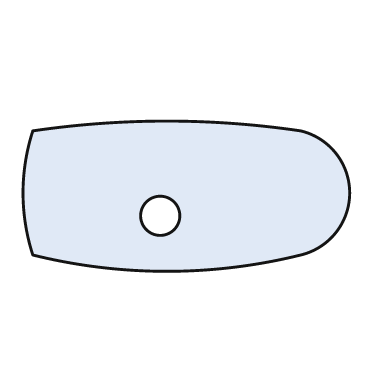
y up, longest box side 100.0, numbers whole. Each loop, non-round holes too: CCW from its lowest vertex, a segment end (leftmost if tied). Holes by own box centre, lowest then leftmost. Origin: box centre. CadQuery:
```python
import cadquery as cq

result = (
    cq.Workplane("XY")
    .moveTo(-47.0, -18.0)
    .threePointArc((-6.0, -23.0), (35.0, -18.0))
    .threePointArc((50.0, 1.0), (35.0, 20.0))
    .threePointArc((-6.0, 23.0), (-47.0, 20.0))
    .threePointArc((-50.0, 1.0), (-47.0, -18.0))
    .close()
    .moveTo(-8.0, -6.0)
    .circle(6.0)
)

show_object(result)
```